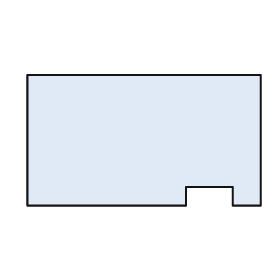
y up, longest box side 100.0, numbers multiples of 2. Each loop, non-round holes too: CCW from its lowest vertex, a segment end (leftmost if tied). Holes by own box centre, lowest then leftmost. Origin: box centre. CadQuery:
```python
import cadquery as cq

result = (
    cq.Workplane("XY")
    .moveTo(-50.0, -28.0)
    .lineTo(18.0, -28.0)
    .lineTo(18.0, -20.0)
    .lineTo(38.0, -20.0)
    .lineTo(38.0, -28.0)
    .lineTo(50.0, -28.0)
    .lineTo(50.0, 28.0)
    .lineTo(-50.0, 28.0)
    .close()
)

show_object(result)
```